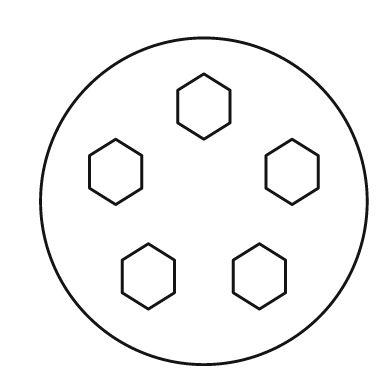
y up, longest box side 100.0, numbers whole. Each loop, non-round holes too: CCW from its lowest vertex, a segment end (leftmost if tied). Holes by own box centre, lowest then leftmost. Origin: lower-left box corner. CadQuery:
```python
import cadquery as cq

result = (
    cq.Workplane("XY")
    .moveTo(50.0, 50.0)
    .circle(50.0)
    .moveTo(33.0, 17.0)
    .lineTo(41.0, 22.0)
    .lineTo(41.0, 32.0)
    .lineTo(33.0, 37.0)
    .lineTo(25.0, 32.0)
    .lineTo(25.0, 22.0)
    .close()
    .moveTo(67.0, 17.0)
    .lineTo(75.0, 22.0)
    .lineTo(75.0, 32.0)
    .lineTo(67.0, 37.0)
    .lineTo(59.0, 32.0)
    .lineTo(59.0, 22.0)
    .close()
    .moveTo(23.0, 49.0)
    .lineTo(31.0, 54.0)
    .lineTo(31.0, 64.0)
    .lineTo(23.0, 69.0)
    .lineTo(15.0, 64.0)
    .lineTo(15.0, 54.0)
    .close()
    .moveTo(77.0, 49.0)
    .lineTo(85.0, 54.0)
    .lineTo(85.0, 64.0)
    .lineTo(77.0, 69.0)
    .lineTo(69.0, 64.0)
    .lineTo(69.0, 54.0)
    .close()
    .moveTo(50.0, 69.0)
    .lineTo(58.0, 74.0)
    .lineTo(58.0, 84.0)
    .lineTo(50.0, 89.0)
    .lineTo(42.0, 84.0)
    .lineTo(42.0, 74.0)
    .close()
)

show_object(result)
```